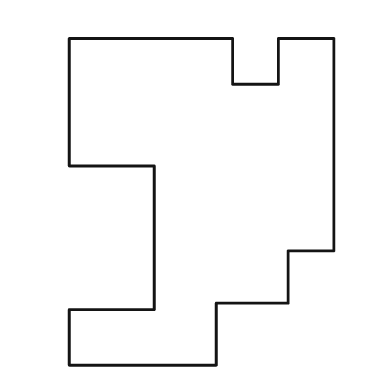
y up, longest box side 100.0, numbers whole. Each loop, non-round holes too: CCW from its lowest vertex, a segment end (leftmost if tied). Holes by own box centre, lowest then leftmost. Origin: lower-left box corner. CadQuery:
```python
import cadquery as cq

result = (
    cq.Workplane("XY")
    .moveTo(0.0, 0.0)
    .lineTo(45.0, 0.0)
    .lineTo(45.0, 19.0)
    .lineTo(67.0, 19.0)
    .lineTo(67.0, 35.0)
    .lineTo(81.0, 35.0)
    .lineTo(81.0, 100.0)
    .lineTo(64.0, 100.0)
    .lineTo(64.0, 86.0)
    .lineTo(50.0, 86.0)
    .lineTo(50.0, 100.0)
    .lineTo(0.0, 100.0)
    .lineTo(0.0, 61.0)
    .lineTo(26.0, 61.0)
    .lineTo(26.0, 17.0)
    .lineTo(0.0, 17.0)
    .close()
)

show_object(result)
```